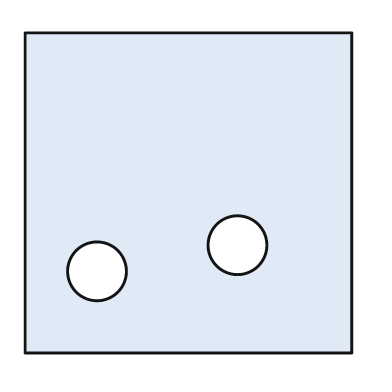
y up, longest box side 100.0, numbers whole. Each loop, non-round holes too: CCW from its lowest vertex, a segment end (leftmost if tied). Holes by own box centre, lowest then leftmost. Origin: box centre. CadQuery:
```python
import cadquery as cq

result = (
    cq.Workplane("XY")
    .moveTo(-50.0, -49.0)
    .lineTo(50.0, -49.0)
    .lineTo(50.0, 49.0)
    .lineTo(-50.0, 49.0)
    .close()
    .moveTo(-28.0, -24.0)
    .circle(9.0)
    .moveTo(15.0, -16.0)
    .circle(9.0)
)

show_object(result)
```